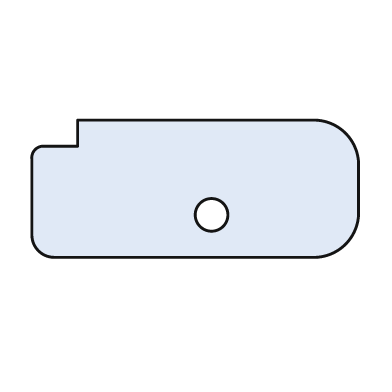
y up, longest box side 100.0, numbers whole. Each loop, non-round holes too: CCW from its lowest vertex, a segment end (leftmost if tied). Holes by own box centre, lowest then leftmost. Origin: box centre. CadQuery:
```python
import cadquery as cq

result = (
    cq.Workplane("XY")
    .moveTo(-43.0, -21.0)
    .lineTo(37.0, -21.0)
    .threePointArc((46.0, -17.0), (50.0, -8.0))
    .lineTo(50.0, 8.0)
    .threePointArc((46.0, 17.0), (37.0, 21.0))
    .lineTo(-36.0, 21.0)
    .lineTo(-36.0, 13.0)
    .lineTo(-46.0, 13.0)
    .threePointArc((-49.0, 12.0), (-50.0, 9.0))
    .lineTo(-50.0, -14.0)
    .threePointArc((-48.0, -19.0), (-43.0, -21.0))
    .close()
    .moveTo(5.0, -8.0)
    .circle(5.0)
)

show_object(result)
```